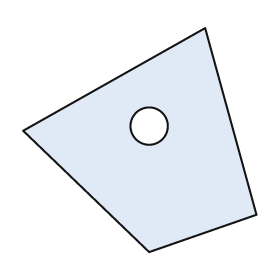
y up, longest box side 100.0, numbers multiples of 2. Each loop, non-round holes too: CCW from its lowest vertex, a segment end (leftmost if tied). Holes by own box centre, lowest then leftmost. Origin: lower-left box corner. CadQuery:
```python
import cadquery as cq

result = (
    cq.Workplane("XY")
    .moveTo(54.0, 0.0)
    .lineTo(100.0, 16.0)
    .lineTo(78.0, 96.0)
    .lineTo(0.0, 52.0)
    .close()
    .moveTo(54.0, 54.0)
    .circle(8.0)
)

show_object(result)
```